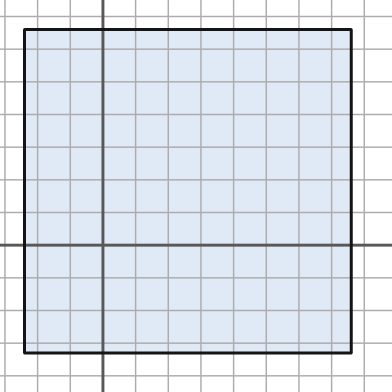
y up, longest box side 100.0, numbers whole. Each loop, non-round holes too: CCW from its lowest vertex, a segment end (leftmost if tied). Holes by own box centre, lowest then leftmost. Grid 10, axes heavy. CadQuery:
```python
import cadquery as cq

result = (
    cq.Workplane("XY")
    .moveTo(-24.0, -33.0)
    .lineTo(76.0, -33.0)
    .lineTo(76.0, 66.0)
    .lineTo(-24.0, 66.0)
    .close()
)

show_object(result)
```